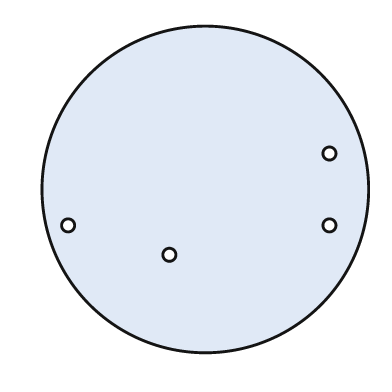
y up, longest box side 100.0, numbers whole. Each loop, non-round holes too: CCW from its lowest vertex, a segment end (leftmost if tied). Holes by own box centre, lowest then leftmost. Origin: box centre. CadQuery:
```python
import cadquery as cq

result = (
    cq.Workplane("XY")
    .moveTo(0.0, 0.0)
    .circle(50.0)
    .moveTo(-11.0, -20.0)
    .circle(2.0)
    .moveTo(-42.0, -11.0)
    .circle(2.0)
    .moveTo(38.0, -11.0)
    .circle(2.0)
    .moveTo(38.0, 11.0)
    .circle(2.0)
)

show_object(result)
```